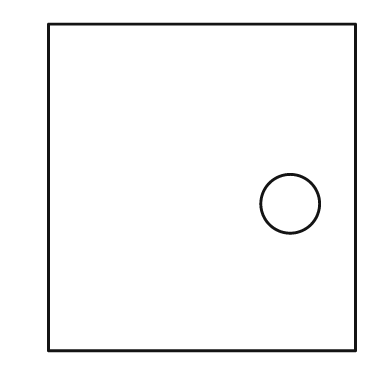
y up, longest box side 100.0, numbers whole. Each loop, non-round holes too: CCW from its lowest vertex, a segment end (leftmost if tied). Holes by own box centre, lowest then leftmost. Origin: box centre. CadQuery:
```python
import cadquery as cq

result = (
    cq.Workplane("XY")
    .moveTo(-47.0, -50.0)
    .lineTo(47.0, -50.0)
    .lineTo(47.0, 50.0)
    .lineTo(-47.0, 50.0)
    .close()
    .moveTo(27.0, -5.0)
    .circle(9.0)
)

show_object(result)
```